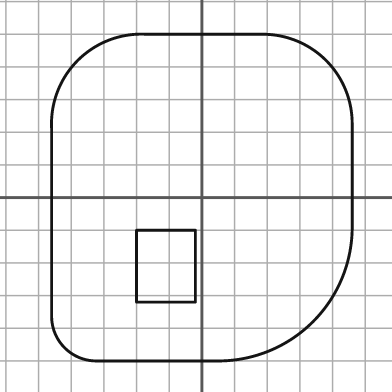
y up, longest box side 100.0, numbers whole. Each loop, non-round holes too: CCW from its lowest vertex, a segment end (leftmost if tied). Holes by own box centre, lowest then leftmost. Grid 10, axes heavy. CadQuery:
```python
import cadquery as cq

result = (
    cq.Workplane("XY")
    .moveTo(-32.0, -50.0)
    .lineTo(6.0, -50.0)
    .threePointArc((34.0, -38.0), (46.0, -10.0))
    .lineTo(46.0, 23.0)
    .threePointArc((38.0, 42.0), (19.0, 50.0))
    .lineTo(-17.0, 50.0)
    .threePointArc((-38.0, 42.0), (-46.0, 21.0))
    .lineTo(-46.0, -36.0)
    .threePointArc((-42.0, -46.0), (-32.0, -50.0))
    .close()
    .moveTo(-20.0, -32.0)
    .lineTo(-2.0, -32.0)
    .lineTo(-2.0, -10.0)
    .lineTo(-20.0, -10.0)
    .close()
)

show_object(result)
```